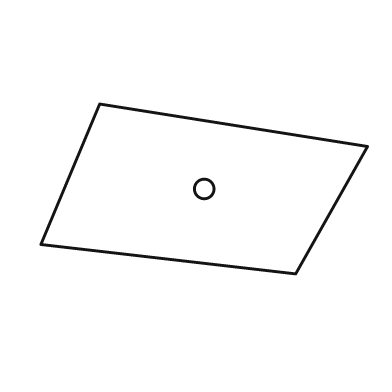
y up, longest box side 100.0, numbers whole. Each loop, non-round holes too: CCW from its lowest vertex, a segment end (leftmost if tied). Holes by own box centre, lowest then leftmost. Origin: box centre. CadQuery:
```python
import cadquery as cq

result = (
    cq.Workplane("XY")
    .moveTo(28.0, -26.0)
    .lineTo(50.0, 13.0)
    .lineTo(-32.0, 26.0)
    .lineTo(-50.0, -17.0)
    .close()
    .moveTo(0.0, 0.0)
    .circle(3.0)
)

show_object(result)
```